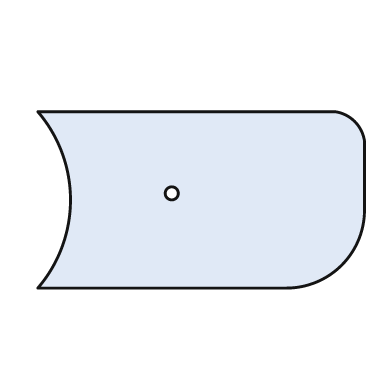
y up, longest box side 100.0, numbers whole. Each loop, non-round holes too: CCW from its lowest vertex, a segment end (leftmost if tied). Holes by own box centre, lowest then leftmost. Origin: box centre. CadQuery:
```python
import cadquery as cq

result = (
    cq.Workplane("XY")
    .moveTo(-50.0, -27.0)
    .lineTo(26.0, -27.0)
    .threePointArc((43.0, -20.0), (50.0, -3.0))
    .lineTo(50.0, 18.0)
    .threePointArc((47.0, 24.0), (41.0, 27.0))
    .lineTo(-50.0, 27.0)
    .threePointArc((-40.0, 0.0), (-50.0, -27.0))
    .close()
    .moveTo(-9.0, 2.0)
    .circle(2.0)
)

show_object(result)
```